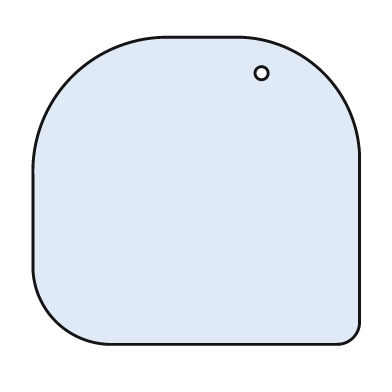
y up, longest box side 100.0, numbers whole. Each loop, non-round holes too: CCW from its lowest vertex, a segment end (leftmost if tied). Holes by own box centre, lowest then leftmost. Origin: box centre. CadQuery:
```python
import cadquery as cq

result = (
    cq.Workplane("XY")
    .moveTo(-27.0, -47.0)
    .lineTo(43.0, -47.0)
    .threePointArc((48.0, -45.0), (50.0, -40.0))
    .lineTo(50.0, 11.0)
    .threePointArc((39.0, 36.0), (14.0, 47.0))
    .lineTo(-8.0, 47.0)
    .threePointArc((-38.0, 35.0), (-50.0, 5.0))
    .lineTo(-50.0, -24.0)
    .threePointArc((-43.0, -40.0), (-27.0, -47.0))
    .close()
    .moveTo(20.0, 36.0)
    .circle(2.0)
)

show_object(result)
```